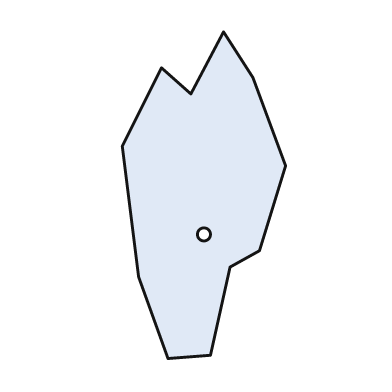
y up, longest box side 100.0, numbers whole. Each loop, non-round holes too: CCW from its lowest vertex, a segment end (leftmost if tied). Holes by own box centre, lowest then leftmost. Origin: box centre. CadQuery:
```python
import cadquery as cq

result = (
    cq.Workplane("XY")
    .moveTo(-11.0, -50.0)
    .lineTo(2.0, -49.0)
    .lineTo(8.0, -22.0)
    .lineTo(17.0, -17.0)
    .lineTo(25.0, 9.0)
    .lineTo(15.0, 36.0)
    .lineTo(6.0, 50.0)
    .lineTo(-4.0, 31.0)
    .lineTo(-13.0, 39.0)
    .lineTo(-25.0, 15.0)
    .lineTo(-20.0, -25.0)
    .close()
    .moveTo(0.0, -12.0)
    .circle(2.0)
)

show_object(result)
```